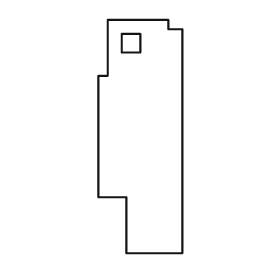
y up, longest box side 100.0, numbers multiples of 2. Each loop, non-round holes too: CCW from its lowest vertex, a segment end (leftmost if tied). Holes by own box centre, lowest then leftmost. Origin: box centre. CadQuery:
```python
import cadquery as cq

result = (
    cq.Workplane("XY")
    .moveTo(-6.0, -50.0)
    .lineTo(18.0, -50.0)
    .lineTo(18.0, 46.0)
    .lineTo(12.0, 46.0)
    .lineTo(12.0, 50.0)
    .lineTo(-14.0, 50.0)
    .lineTo(-14.0, 26.0)
    .lineTo(-18.0, 26.0)
    .lineTo(-18.0, -26.0)
    .lineTo(-6.0, -26.0)
    .close()
    .moveTo(-8.0, 36.0)
    .lineTo(0.0, 36.0)
    .lineTo(0.0, 44.0)
    .lineTo(-8.0, 44.0)
    .close()
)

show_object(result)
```